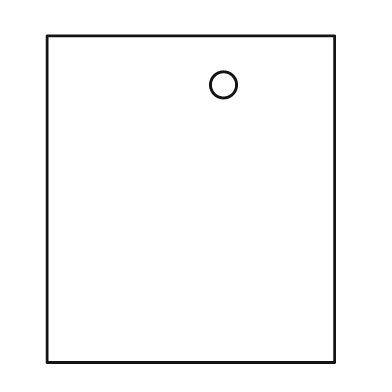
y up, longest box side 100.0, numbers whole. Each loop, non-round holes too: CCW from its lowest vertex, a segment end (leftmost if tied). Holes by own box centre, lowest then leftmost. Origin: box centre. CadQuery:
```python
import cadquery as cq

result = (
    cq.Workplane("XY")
    .moveTo(-44.0, -50.0)
    .lineTo(44.0, -50.0)
    .lineTo(44.0, 50.0)
    .lineTo(-44.0, 50.0)
    .close()
    .moveTo(10.0, 35.0)
    .circle(4.0)
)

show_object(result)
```